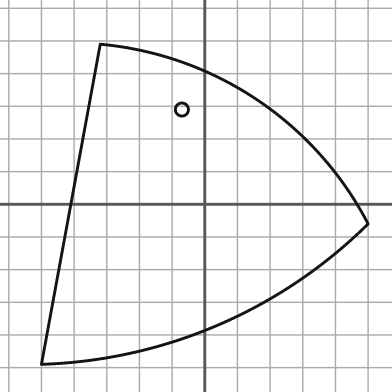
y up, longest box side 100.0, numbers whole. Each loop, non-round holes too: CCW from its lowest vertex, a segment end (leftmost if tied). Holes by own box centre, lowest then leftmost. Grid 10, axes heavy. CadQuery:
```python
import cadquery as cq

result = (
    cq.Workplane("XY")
    .moveTo(-50.0, -49.0)
    .threePointArc((4.0, -37.0), (50.0, -6.0))
    .threePointArc((16.0, 32.0), (-32.0, 49.0))
    .close()
    .moveTo(-7.0, 29.0)
    .circle(2.0)
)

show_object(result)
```